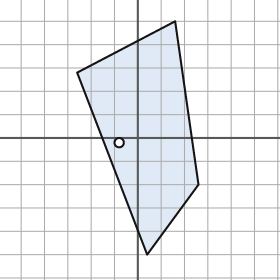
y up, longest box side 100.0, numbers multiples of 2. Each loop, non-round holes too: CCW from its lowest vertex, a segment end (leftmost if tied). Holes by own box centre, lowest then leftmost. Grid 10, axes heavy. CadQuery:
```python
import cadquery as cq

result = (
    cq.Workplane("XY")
    .moveTo(4.0, -50.0)
    .lineTo(26.0, -20.0)
    .lineTo(16.0, 50.0)
    .lineTo(-26.0, 28.0)
    .close()
    .moveTo(-8.0, -2.0)
    .circle(2.0)
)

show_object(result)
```